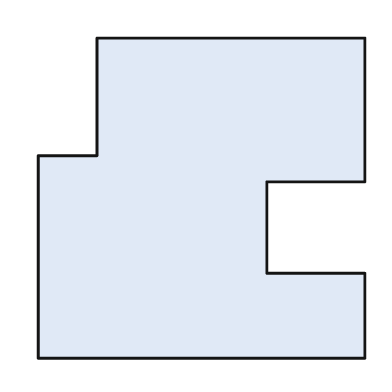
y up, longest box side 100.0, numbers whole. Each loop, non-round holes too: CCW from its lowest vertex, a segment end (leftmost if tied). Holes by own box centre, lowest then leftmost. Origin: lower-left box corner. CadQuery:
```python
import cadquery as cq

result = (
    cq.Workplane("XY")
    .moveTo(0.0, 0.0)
    .lineTo(100.0, 0.0)
    .lineTo(100.0, 26.0)
    .lineTo(70.0, 26.0)
    .lineTo(70.0, 54.0)
    .lineTo(100.0, 54.0)
    .lineTo(100.0, 98.0)
    .lineTo(18.0, 98.0)
    .lineTo(18.0, 62.0)
    .lineTo(0.0, 62.0)
    .close()
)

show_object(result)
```